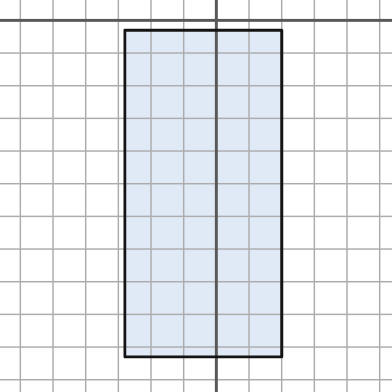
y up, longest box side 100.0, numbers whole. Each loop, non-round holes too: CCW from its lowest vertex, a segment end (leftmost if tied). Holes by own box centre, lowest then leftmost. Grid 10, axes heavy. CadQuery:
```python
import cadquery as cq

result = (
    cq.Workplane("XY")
    .moveTo(-28.0, -103.0)
    .lineTo(20.0, -103.0)
    .lineTo(20.0, -3.0)
    .lineTo(-28.0, -3.0)
    .close()
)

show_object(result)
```